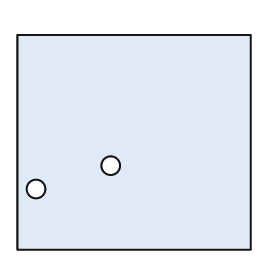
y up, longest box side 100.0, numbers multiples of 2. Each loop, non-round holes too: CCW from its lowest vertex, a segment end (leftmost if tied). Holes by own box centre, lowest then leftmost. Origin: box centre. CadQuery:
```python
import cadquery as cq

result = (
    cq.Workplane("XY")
    .moveTo(-50.0, -46.0)
    .lineTo(50.0, -46.0)
    .lineTo(50.0, 46.0)
    .lineTo(-50.0, 46.0)
    .close()
    .moveTo(-42.0, -20.0)
    .circle(4.0)
    .moveTo(-10.0, -10.0)
    .circle(4.0)
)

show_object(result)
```